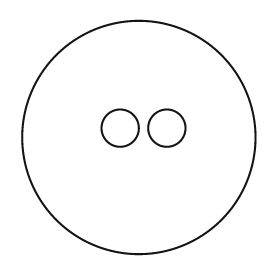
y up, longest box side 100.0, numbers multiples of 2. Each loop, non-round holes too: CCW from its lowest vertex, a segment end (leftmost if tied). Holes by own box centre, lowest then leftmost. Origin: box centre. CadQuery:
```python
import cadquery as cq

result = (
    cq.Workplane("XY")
    .moveTo(0.0, 0.0)
    .circle(50.0)
    .moveTo(-8.0, 4.0)
    .circle(8.0)
    .moveTo(12.0, 4.0)
    .circle(8.0)
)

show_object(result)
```